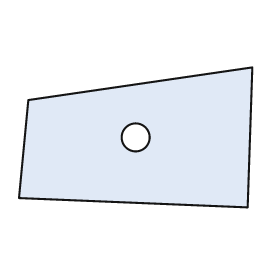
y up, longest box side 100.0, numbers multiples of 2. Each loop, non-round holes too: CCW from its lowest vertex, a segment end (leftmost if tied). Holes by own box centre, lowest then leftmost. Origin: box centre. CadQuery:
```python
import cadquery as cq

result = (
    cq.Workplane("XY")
    .moveTo(48.0, -30.0)
    .lineTo(50.0, 30.0)
    .lineTo(-46.0, 16.0)
    .lineTo(-50.0, -26.0)
    .close()
    .moveTo(0.0, 0.0)
    .circle(6.0)
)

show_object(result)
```